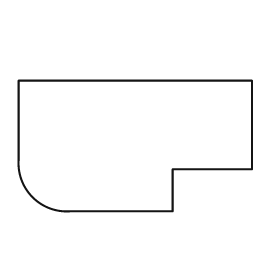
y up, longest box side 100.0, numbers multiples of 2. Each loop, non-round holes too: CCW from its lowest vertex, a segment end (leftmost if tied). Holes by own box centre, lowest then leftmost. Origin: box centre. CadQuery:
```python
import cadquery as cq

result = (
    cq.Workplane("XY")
    .moveTo(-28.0, -28.0)
    .lineTo(16.0, -28.0)
    .lineTo(16.0, -10.0)
    .lineTo(50.0, -10.0)
    .lineTo(50.0, 28.0)
    .lineTo(-50.0, 28.0)
    .lineTo(-50.0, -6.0)
    .threePointArc((-44.0, -22.0), (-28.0, -28.0))
    .close()
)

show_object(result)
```